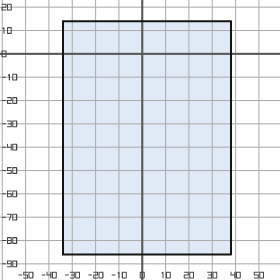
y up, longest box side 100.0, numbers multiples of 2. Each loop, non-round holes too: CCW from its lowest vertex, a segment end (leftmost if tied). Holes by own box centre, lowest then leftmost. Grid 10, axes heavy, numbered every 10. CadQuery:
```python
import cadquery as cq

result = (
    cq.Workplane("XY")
    .moveTo(-34.0, -86.0)
    .lineTo(38.0, -86.0)
    .lineTo(38.0, 14.0)
    .lineTo(-34.0, 14.0)
    .close()
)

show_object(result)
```